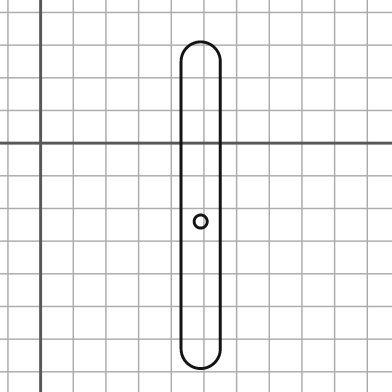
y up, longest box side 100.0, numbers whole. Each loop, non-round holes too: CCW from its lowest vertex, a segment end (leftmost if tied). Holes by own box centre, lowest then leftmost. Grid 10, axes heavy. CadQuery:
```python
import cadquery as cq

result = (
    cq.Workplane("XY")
    .moveTo(43.0, -63.0)
    .threePointArc((49.0, -69.0), (55.0, -63.0))
    .lineTo(55.0, 25.0)
    .threePointArc((49.0, 31.0), (43.0, 25.0))
    .close()
    .moveTo(49.0, -24.0)
    .circle(2.0)
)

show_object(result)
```